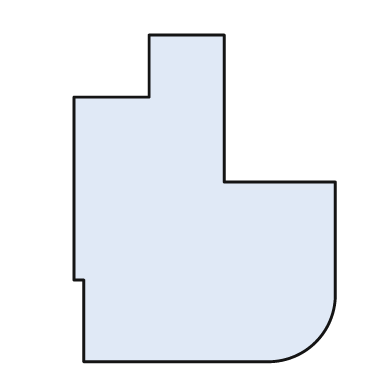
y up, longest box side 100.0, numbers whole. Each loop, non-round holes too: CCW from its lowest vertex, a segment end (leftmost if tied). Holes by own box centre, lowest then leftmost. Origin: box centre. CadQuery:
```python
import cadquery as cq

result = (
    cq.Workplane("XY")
    .moveTo(-37.0, -50.0)
    .lineTo(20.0, -50.0)
    .threePointArc((34.0, -44.0), (40.0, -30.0))
    .lineTo(40.0, 5.0)
    .lineTo(6.0, 5.0)
    .lineTo(6.0, 50.0)
    .lineTo(-17.0, 50.0)
    .lineTo(-17.0, 31.0)
    .lineTo(-40.0, 31.0)
    .lineTo(-40.0, -25.0)
    .lineTo(-37.0, -25.0)
    .close()
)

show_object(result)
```